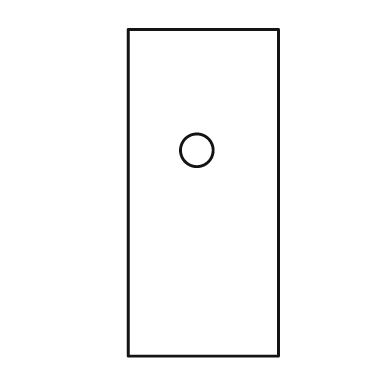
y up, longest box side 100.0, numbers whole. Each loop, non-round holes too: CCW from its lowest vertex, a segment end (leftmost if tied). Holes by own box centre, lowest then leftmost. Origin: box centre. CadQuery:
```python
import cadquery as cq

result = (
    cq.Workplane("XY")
    .moveTo(-23.0, -50.0)
    .lineTo(23.0, -50.0)
    .lineTo(23.0, 50.0)
    .lineTo(-23.0, 50.0)
    .close()
    .moveTo(-2.0, 13.0)
    .circle(5.0)
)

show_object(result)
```